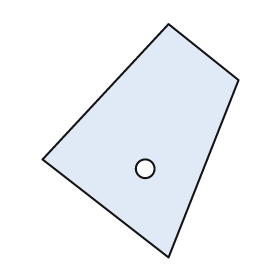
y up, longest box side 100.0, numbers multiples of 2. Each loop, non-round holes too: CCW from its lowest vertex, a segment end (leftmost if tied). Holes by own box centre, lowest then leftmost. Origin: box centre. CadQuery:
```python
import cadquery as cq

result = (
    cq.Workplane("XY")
    .moveTo(12.0, -50.0)
    .lineTo(42.0, 26.0)
    .lineTo(12.0, 50.0)
    .lineTo(-42.0, -8.0)
    .close()
    .moveTo(2.0, -12.0)
    .circle(4.0)
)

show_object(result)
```